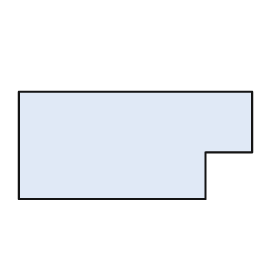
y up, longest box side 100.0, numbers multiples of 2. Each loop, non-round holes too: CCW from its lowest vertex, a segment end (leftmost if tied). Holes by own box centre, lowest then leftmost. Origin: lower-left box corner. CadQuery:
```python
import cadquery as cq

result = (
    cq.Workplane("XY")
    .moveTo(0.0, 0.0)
    .lineTo(80.0, 0.0)
    .lineTo(80.0, 20.0)
    .lineTo(100.0, 20.0)
    .lineTo(100.0, 46.0)
    .lineTo(0.0, 46.0)
    .close()
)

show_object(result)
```